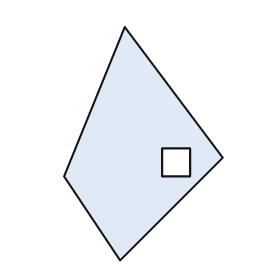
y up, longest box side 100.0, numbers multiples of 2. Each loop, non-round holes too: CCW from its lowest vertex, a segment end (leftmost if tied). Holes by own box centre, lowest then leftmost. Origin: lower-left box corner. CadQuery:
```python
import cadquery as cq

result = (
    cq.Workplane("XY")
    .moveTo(24.0, 0.0)
    .lineTo(68.0, 44.0)
    .lineTo(26.0, 100.0)
    .lineTo(0.0, 36.0)
    .close()
    .moveTo(42.0, 36.0)
    .lineTo(54.0, 36.0)
    .lineTo(54.0, 48.0)
    .lineTo(42.0, 48.0)
    .close()
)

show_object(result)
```